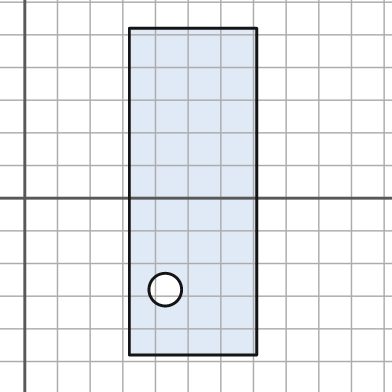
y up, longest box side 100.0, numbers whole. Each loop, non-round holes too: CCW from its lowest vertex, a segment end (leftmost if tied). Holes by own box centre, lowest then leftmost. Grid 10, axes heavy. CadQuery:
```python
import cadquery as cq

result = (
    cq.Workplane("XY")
    .moveTo(32.0, -48.0)
    .lineTo(71.0, -48.0)
    .lineTo(71.0, 52.0)
    .lineTo(32.0, 52.0)
    .close()
    .moveTo(43.0, -28.0)
    .circle(5.0)
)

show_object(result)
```